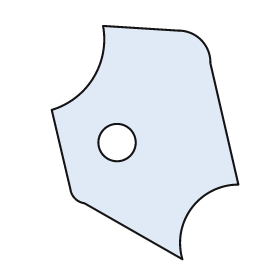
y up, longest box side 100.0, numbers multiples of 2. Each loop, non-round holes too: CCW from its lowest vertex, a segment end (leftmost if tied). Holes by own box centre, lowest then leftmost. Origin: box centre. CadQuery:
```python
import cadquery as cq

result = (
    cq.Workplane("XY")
    .moveTo(16.0, -50.0)
    .threePointArc((20.0, -28.0), (40.0, -18.0))
    .lineTo(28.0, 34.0)
    .threePointArc((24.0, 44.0), (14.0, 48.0))
    .lineTo(-18.0, 50.0)
    .threePointArc((-22.0, 28.0), (-40.0, 14.0))
    .lineTo(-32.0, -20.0)
    .threePointArc((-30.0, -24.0), (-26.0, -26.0))
    .close()
    .moveTo(-12.0, 0.0)
    .circle(8.0)
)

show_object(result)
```